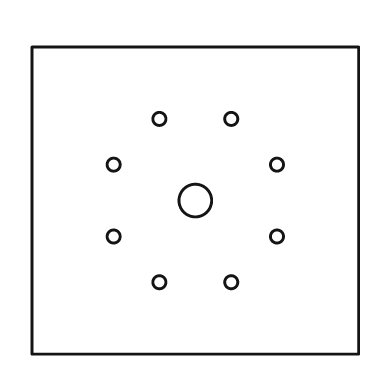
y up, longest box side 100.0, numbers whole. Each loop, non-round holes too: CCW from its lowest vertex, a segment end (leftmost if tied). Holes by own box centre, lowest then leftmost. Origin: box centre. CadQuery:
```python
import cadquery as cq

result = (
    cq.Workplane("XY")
    .moveTo(-50.0, -47.0)
    .lineTo(50.0, -47.0)
    .lineTo(50.0, 47.0)
    .lineTo(-50.0, 47.0)
    .close()
    .moveTo(-11.0, -25.0)
    .circle(2.0)
    .moveTo(11.0, -25.0)
    .circle(2.0)
    .moveTo(-25.0, -11.0)
    .circle(2.0)
    .moveTo(25.0, -11.0)
    .circle(2.0)
    .moveTo(0.0, 0.0)
    .circle(5.0)
    .moveTo(-25.0, 11.0)
    .circle(2.0)
    .moveTo(25.0, 11.0)
    .circle(2.0)
    .moveTo(-11.0, 25.0)
    .circle(2.0)
    .moveTo(11.0, 25.0)
    .circle(2.0)
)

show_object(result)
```